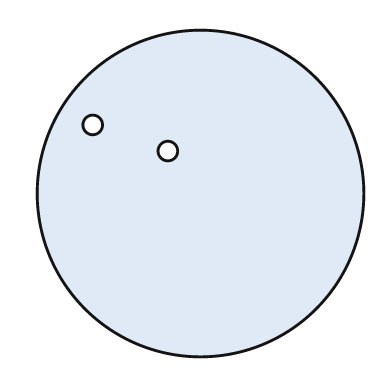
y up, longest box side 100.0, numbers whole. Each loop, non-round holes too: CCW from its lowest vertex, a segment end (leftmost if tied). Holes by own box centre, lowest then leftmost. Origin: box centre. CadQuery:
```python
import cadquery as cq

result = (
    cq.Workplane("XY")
    .moveTo(0.0, 0.0)
    .circle(50.0)
    .moveTo(-10.0, 13.0)
    .circle(3.0)
    .moveTo(-33.0, 21.0)
    .circle(3.0)
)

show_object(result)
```